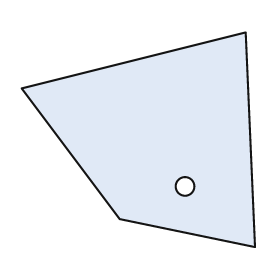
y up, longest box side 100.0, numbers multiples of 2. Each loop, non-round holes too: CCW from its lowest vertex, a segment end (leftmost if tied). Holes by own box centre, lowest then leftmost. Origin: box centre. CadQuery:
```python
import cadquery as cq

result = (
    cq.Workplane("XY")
    .moveTo(50.0, -46.0)
    .lineTo(46.0, 46.0)
    .lineTo(-50.0, 22.0)
    .lineTo(-8.0, -34.0)
    .close()
    .moveTo(20.0, -20.0)
    .circle(4.0)
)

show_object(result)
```